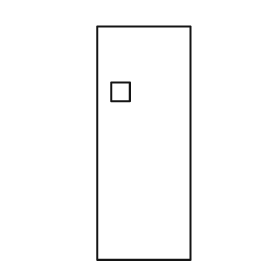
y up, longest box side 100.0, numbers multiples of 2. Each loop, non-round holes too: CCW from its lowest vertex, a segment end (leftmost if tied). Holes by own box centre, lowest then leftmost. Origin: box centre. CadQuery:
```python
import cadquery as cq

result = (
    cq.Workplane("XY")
    .moveTo(-20.0, -50.0)
    .lineTo(20.0, -50.0)
    .lineTo(20.0, 50.0)
    .lineTo(-20.0, 50.0)
    .close()
    .moveTo(-14.0, 18.0)
    .lineTo(-6.0, 18.0)
    .lineTo(-6.0, 26.0)
    .lineTo(-14.0, 26.0)
    .close()
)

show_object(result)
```